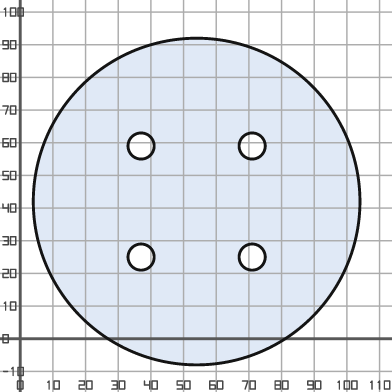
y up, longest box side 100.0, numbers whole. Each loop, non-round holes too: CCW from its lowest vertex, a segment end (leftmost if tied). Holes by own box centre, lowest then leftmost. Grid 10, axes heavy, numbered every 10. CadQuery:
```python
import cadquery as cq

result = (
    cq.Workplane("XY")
    .moveTo(54.0, 42.0)
    .circle(50.0)
    .moveTo(37.0, 25.0)
    .circle(4.0)
    .moveTo(71.0, 25.0)
    .circle(4.0)
    .moveTo(37.0, 59.0)
    .circle(4.0)
    .moveTo(71.0, 59.0)
    .circle(4.0)
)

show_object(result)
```